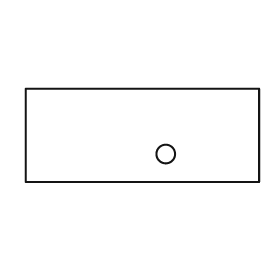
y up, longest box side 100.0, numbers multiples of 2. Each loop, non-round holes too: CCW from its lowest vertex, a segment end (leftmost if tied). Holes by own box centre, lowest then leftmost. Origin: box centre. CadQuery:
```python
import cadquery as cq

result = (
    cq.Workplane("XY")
    .moveTo(-50.0, -20.0)
    .lineTo(50.0, -20.0)
    .lineTo(50.0, 20.0)
    .lineTo(-50.0, 20.0)
    .close()
    .moveTo(10.0, -8.0)
    .circle(4.0)
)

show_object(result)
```